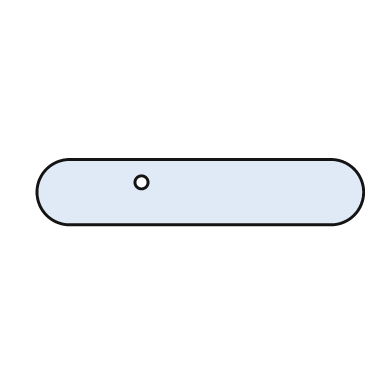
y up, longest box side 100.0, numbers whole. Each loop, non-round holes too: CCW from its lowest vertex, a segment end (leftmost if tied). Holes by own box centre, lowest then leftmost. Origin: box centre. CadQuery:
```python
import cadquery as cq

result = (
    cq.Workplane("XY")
    .moveTo(-40.0, -10.0)
    .lineTo(40.0, -10.0)
    .threePointArc((50.0, 0.0), (40.0, 10.0))
    .lineTo(-40.0, 10.0)
    .threePointArc((-50.0, 0.0), (-40.0, -10.0))
    .close()
    .moveTo(-18.0, 3.0)
    .circle(2.0)
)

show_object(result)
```